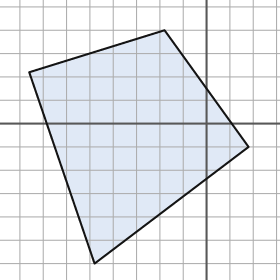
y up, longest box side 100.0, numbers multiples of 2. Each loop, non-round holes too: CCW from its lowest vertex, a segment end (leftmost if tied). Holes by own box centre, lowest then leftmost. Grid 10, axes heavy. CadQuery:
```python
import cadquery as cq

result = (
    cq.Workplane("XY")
    .moveTo(-48.0, -60.0)
    .lineTo(18.0, -10.0)
    .lineTo(-18.0, 40.0)
    .lineTo(-76.0, 22.0)
    .close()
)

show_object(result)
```